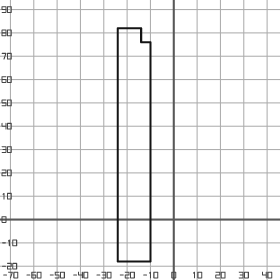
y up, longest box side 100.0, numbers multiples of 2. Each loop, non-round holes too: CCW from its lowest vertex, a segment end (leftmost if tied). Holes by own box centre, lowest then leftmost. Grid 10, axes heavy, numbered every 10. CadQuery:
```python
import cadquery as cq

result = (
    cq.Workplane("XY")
    .moveTo(-24.0, -18.0)
    .lineTo(-10.0, -18.0)
    .lineTo(-10.0, 76.0)
    .lineTo(-14.0, 76.0)
    .lineTo(-14.0, 82.0)
    .lineTo(-24.0, 82.0)
    .close()
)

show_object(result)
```